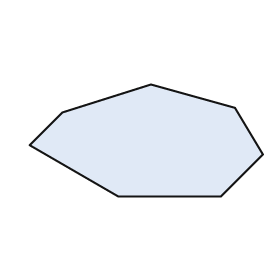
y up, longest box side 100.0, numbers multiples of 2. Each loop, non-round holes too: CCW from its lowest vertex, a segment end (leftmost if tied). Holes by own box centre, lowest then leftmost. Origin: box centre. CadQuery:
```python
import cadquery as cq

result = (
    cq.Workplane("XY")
    .moveTo(-12.0, -24.0)
    .lineTo(32.0, -24.0)
    .lineTo(50.0, -6.0)
    .lineTo(38.0, 14.0)
    .lineTo(2.0, 24.0)
    .lineTo(-36.0, 12.0)
    .lineTo(-50.0, -2.0)
    .close()
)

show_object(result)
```